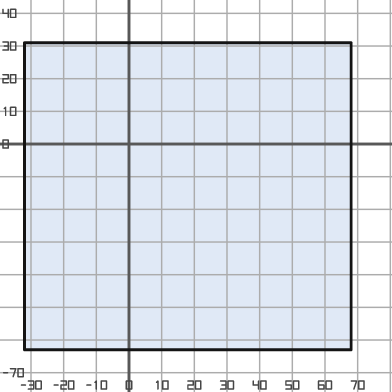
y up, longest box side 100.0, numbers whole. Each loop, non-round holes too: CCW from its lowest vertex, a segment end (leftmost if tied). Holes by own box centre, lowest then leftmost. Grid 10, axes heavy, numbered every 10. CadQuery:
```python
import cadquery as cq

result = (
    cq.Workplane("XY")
    .moveTo(-32.0, -63.0)
    .lineTo(68.0, -63.0)
    .lineTo(68.0, 31.0)
    .lineTo(-32.0, 31.0)
    .close()
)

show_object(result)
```